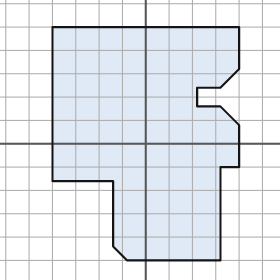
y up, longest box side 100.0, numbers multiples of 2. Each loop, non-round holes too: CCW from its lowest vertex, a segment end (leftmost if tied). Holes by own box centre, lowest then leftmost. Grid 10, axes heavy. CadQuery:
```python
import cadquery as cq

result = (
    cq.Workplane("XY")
    .moveTo(-8.0, -50.0)
    .lineTo(32.0, -50.0)
    .lineTo(32.0, -10.0)
    .lineTo(40.0, -10.0)
    .lineTo(40.0, 8.0)
    .lineTo(32.0, 16.0)
    .lineTo(22.0, 16.0)
    .lineTo(22.0, 24.0)
    .lineTo(32.0, 24.0)
    .lineTo(40.0, 32.0)
    .lineTo(40.0, 50.0)
    .lineTo(-40.0, 50.0)
    .lineTo(-40.0, -16.0)
    .lineTo(-14.0, -16.0)
    .lineTo(-14.0, -44.0)
    .close()
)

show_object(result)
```